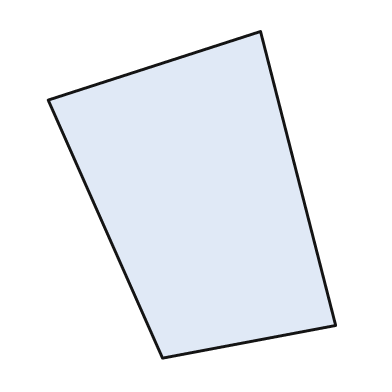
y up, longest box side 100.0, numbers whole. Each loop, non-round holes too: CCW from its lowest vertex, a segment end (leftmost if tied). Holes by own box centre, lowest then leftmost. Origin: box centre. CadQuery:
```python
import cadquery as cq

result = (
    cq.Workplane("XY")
    .moveTo(-9.0, -50.0)
    .lineTo(44.0, -40.0)
    .lineTo(21.0, 50.0)
    .lineTo(-44.0, 29.0)
    .close()
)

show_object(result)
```